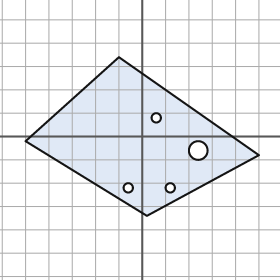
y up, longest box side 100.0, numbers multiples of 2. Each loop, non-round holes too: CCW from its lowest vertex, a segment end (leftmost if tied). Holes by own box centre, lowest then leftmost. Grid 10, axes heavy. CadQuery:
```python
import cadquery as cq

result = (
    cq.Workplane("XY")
    .moveTo(2.0, -34.0)
    .lineTo(50.0, -8.0)
    .lineTo(-10.0, 34.0)
    .lineTo(-50.0, -2.0)
    .close()
    .moveTo(-6.0, -22.0)
    .circle(2.0)
    .moveTo(12.0, -22.0)
    .circle(2.0)
    .moveTo(24.0, -6.0)
    .circle(4.0)
    .moveTo(6.0, 8.0)
    .circle(2.0)
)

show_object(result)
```